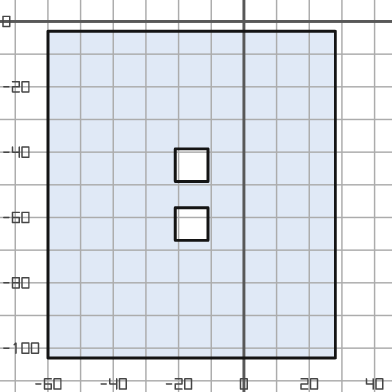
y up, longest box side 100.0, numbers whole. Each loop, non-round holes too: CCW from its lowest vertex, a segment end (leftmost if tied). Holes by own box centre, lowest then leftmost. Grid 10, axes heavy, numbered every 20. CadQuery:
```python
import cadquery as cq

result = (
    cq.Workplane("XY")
    .moveTo(-60.0, -103.0)
    .lineTo(28.0, -103.0)
    .lineTo(28.0, -3.0)
    .lineTo(-60.0, -3.0)
    .close()
    .moveTo(-21.0, -67.0)
    .lineTo(-11.0, -67.0)
    .lineTo(-11.0, -57.0)
    .lineTo(-21.0, -57.0)
    .close()
    .moveTo(-21.0, -49.0)
    .lineTo(-11.0, -49.0)
    .lineTo(-11.0, -39.0)
    .lineTo(-21.0, -39.0)
    .close()
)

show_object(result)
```